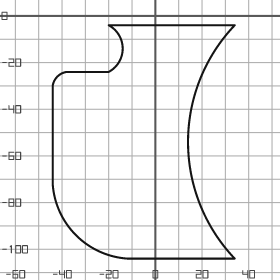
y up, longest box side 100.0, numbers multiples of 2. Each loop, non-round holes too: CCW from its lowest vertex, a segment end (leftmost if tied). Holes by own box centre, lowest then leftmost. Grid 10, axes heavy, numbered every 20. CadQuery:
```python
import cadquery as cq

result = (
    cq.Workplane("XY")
    .moveTo(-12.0, -104.0)
    .lineTo(34.0, -104.0)
    .threePointArc((14.0, -54.0), (34.0, -4.0))
    .lineTo(-20.0, -4.0)
    .threePointArc((-14.0, -14.0), (-20.0, -24.0))
    .lineTo(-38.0, -24.0)
    .threePointArc((-42.0, -26.0), (-44.0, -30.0))
    .lineTo(-44.0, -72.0)
    .threePointArc((-34.0, -94.0), (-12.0, -104.0))
    .close()
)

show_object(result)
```